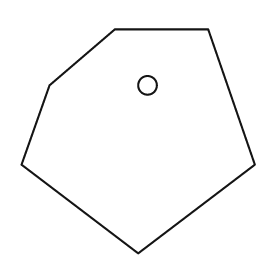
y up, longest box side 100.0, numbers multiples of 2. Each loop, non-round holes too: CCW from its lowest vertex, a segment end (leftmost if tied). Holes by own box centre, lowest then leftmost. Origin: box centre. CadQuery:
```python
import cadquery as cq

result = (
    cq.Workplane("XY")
    .moveTo(0.0, -48.0)
    .lineTo(50.0, -10.0)
    .lineTo(30.0, 48.0)
    .lineTo(-10.0, 48.0)
    .lineTo(-38.0, 24.0)
    .lineTo(-50.0, -10.0)
    .close()
    .moveTo(4.0, 24.0)
    .circle(4.0)
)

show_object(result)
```